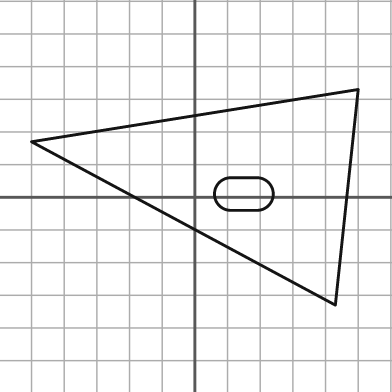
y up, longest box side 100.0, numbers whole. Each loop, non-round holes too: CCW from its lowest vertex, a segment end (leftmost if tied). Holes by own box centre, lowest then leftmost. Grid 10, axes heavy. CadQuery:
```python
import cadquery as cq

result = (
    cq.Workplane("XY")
    .moveTo(43.0, -33.0)
    .lineTo(50.0, 33.0)
    .lineTo(-50.0, 17.0)
    .close()
    .moveTo(11.0, -4.0)
    .lineTo(19.0, -4.0)
    .threePointArc((24.0, 1.0), (19.0, 6.0))
    .lineTo(11.0, 6.0)
    .threePointArc((6.0, 1.0), (11.0, -4.0))
    .close()
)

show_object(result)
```